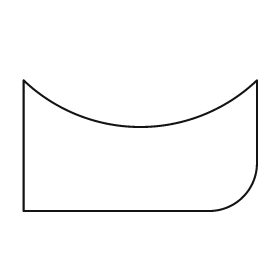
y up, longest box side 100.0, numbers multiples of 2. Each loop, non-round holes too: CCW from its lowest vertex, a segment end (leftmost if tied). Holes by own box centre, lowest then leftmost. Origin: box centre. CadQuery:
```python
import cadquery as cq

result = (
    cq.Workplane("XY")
    .moveTo(-50.0, -28.0)
    .lineTo(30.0, -28.0)
    .threePointArc((44.0, -22.0), (50.0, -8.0))
    .lineTo(50.0, 28.0)
    .threePointArc((0.0, 8.0), (-50.0, 28.0))
    .close()
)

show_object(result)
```